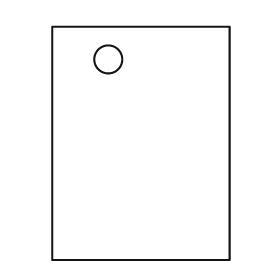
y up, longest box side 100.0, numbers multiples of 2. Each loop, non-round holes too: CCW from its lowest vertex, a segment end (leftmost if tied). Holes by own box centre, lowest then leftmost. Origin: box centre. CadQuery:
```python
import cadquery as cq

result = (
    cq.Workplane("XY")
    .moveTo(-38.0, -50.0)
    .lineTo(38.0, -50.0)
    .lineTo(38.0, 50.0)
    .lineTo(-38.0, 50.0)
    .close()
    .moveTo(-14.0, 36.0)
    .circle(6.0)
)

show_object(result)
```